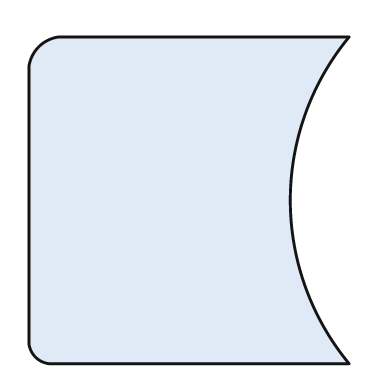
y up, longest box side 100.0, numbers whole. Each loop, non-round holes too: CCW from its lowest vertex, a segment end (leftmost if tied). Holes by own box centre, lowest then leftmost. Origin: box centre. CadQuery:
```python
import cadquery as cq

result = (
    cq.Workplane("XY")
    .moveTo(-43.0, -50.0)
    .lineTo(49.0, -50.0)
    .threePointArc((31.0, 0.0), (49.0, 50.0))
    .lineTo(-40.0, 50.0)
    .threePointArc((-46.0, 47.0), (-49.0, 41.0))
    .lineTo(-49.0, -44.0)
    .threePointArc((-47.0, -48.0), (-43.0, -50.0))
    .close()
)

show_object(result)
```